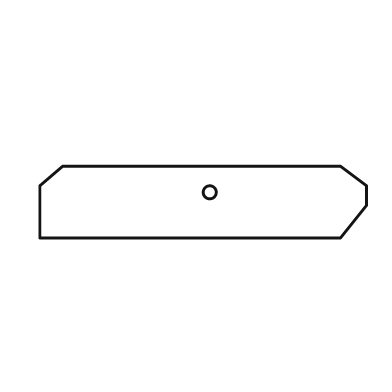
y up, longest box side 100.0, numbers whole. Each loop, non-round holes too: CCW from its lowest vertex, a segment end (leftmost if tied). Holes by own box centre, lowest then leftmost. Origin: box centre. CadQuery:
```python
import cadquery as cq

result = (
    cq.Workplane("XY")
    .moveTo(-50.0, -11.0)
    .lineTo(42.0, -11.0)
    .lineTo(50.0, -1.0)
    .lineTo(50.0, 5.0)
    .lineTo(42.0, 11.0)
    .lineTo(-43.0, 11.0)
    .lineTo(-50.0, 5.0)
    .close()
    .moveTo(2.0, 3.0)
    .circle(2.0)
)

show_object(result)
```